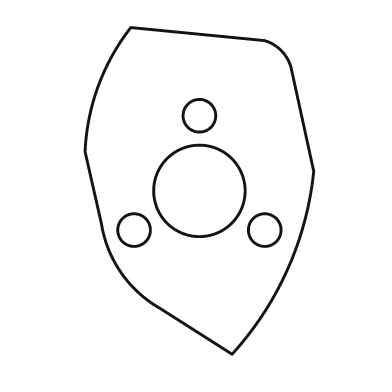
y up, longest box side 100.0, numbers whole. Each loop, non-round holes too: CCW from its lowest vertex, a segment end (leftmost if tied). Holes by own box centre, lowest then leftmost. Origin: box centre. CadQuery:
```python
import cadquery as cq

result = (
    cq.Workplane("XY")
    .moveTo(10.0, -50.0)
    .threePointArc((27.0, -24.0), (35.0, 6.0))
    .lineTo(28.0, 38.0)
    .threePointArc((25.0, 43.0), (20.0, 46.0))
    .lineTo(-21.0, 50.0)
    .threePointArc((-31.0, 32.0), (-35.0, 12.0))
    .lineTo(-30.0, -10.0)
    .threePointArc((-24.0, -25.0), (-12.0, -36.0))
    .close()
    .moveTo(-20.0, -12.0)
    .circle(5.0)
    .moveTo(20.0, -12.0)
    .circle(5.0)
    .moveTo(0.0, 0.0)
    .circle(14.0)
    .moveTo(0.0, 23.0)
    .circle(5.0)
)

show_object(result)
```